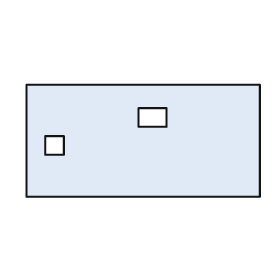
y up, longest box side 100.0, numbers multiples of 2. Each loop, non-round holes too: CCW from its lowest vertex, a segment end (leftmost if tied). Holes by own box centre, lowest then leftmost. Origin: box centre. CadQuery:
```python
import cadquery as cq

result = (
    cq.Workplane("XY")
    .moveTo(-50.0, -24.0)
    .lineTo(50.0, -24.0)
    .lineTo(50.0, 24.0)
    .lineTo(-50.0, 24.0)
    .close()
    .moveTo(-42.0, -6.0)
    .lineTo(-34.0, -6.0)
    .lineTo(-34.0, 2.0)
    .lineTo(-42.0, 2.0)
    .close()
    .moveTo(-2.0, 6.0)
    .lineTo(10.0, 6.0)
    .lineTo(10.0, 14.0)
    .lineTo(-2.0, 14.0)
    .close()
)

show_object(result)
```